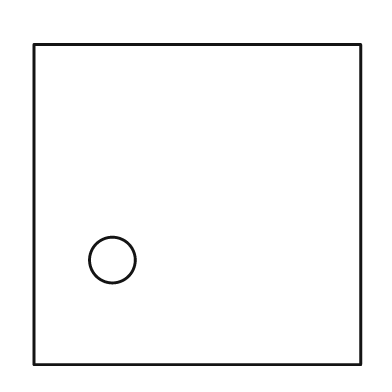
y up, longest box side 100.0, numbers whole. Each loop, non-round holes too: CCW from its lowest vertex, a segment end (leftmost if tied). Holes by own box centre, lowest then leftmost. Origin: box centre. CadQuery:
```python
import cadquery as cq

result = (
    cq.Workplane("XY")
    .moveTo(-50.0, -49.0)
    .lineTo(50.0, -49.0)
    .lineTo(50.0, 49.0)
    .lineTo(-50.0, 49.0)
    .close()
    .moveTo(-26.0, -17.0)
    .circle(7.0)
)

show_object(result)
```